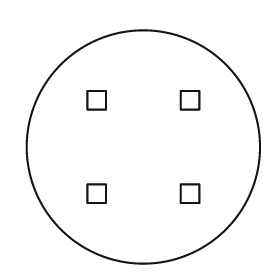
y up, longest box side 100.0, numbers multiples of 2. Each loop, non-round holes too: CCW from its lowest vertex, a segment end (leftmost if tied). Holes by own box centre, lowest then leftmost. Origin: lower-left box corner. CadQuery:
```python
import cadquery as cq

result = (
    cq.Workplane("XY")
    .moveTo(50.0, 50.0)
    .circle(50.0)
    .moveTo(26.0, 26.0)
    .lineTo(34.0, 26.0)
    .lineTo(34.0, 34.0)
    .lineTo(26.0, 34.0)
    .close()
    .moveTo(66.0, 26.0)
    .lineTo(74.0, 26.0)
    .lineTo(74.0, 34.0)
    .lineTo(66.0, 34.0)
    .close()
    .moveTo(26.0, 66.0)
    .lineTo(34.0, 66.0)
    .lineTo(34.0, 74.0)
    .lineTo(26.0, 74.0)
    .close()
    .moveTo(66.0, 66.0)
    .lineTo(74.0, 66.0)
    .lineTo(74.0, 74.0)
    .lineTo(66.0, 74.0)
    .close()
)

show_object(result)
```